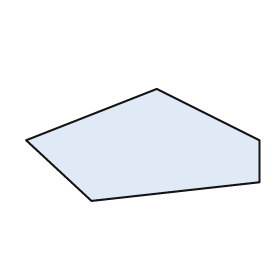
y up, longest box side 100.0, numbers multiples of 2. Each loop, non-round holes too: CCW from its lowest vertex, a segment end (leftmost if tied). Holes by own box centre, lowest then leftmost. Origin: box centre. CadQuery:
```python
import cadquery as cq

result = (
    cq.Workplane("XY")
    .moveTo(-22.0, -24.0)
    .lineTo(50.0, -16.0)
    .lineTo(50.0, 2.0)
    .lineTo(6.0, 24.0)
    .lineTo(-50.0, 2.0)
    .close()
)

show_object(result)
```